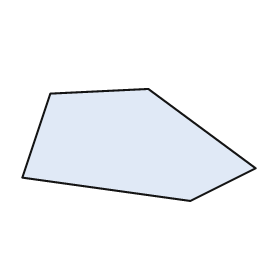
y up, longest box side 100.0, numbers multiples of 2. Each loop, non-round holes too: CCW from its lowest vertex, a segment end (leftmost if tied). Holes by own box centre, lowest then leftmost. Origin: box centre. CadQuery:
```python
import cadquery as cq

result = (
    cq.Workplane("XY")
    .moveTo(22.0, -24.0)
    .lineTo(50.0, -10.0)
    .lineTo(4.0, 24.0)
    .lineTo(-38.0, 22.0)
    .lineTo(-50.0, -14.0)
    .close()
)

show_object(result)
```